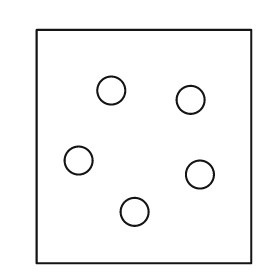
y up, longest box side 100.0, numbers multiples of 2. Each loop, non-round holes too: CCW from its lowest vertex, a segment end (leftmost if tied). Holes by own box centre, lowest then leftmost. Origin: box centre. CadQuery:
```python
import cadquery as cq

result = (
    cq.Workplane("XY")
    .moveTo(-46.0, -50.0)
    .lineTo(46.0, -50.0)
    .lineTo(46.0, 50.0)
    .lineTo(-46.0, 50.0)
    .close()
    .moveTo(-4.0, -28.0)
    .circle(6.0)
    .moveTo(24.0, -12.0)
    .circle(6.0)
    .moveTo(-28.0, -6.0)
    .circle(6.0)
    .moveTo(20.0, 20.0)
    .circle(6.0)
    .moveTo(-14.0, 24.0)
    .circle(6.0)
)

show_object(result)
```